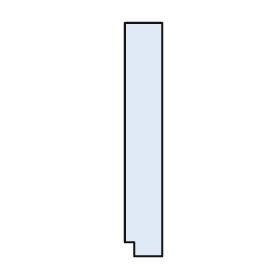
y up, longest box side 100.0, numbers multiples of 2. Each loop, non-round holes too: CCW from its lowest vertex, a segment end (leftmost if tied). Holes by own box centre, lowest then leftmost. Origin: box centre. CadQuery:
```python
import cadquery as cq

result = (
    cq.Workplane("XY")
    .moveTo(-4.0, -50.0)
    .lineTo(8.0, -50.0)
    .lineTo(8.0, 50.0)
    .lineTo(-8.0, 50.0)
    .lineTo(-8.0, -44.0)
    .lineTo(-4.0, -44.0)
    .close()
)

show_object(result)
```